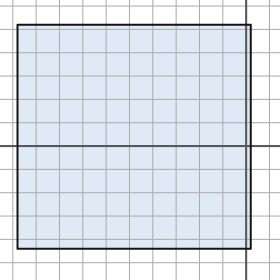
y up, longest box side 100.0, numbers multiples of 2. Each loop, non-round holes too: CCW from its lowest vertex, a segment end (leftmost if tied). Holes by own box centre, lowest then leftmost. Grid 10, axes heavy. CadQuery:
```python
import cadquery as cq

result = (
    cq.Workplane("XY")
    .moveTo(-98.0, -44.0)
    .lineTo(2.0, -44.0)
    .lineTo(2.0, 52.0)
    .lineTo(-98.0, 52.0)
    .close()
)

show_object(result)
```